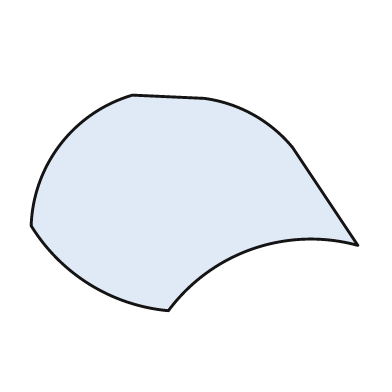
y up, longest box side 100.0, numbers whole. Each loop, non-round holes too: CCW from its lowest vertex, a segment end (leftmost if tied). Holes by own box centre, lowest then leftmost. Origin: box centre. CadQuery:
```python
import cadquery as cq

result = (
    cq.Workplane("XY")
    .moveTo(-8.0, -33.0)
    .threePointArc((18.0, -14.0), (50.0, -13.0))
    .lineTo(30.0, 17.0)
    .threePointArc((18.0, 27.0), (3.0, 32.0))
    .lineTo(-19.0, 33.0)
    .threePointArc((-41.0, 18.0), (-50.0, -7.0))
    .threePointArc((-32.0, -25.0), (-8.0, -33.0))
    .close()
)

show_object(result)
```